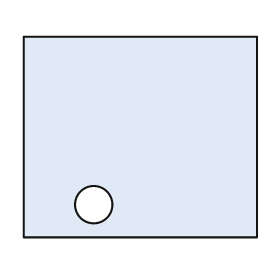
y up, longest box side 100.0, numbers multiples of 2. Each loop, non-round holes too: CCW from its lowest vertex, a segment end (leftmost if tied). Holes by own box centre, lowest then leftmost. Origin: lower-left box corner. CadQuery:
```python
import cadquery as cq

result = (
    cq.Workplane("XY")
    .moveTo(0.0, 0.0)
    .lineTo(100.0, 0.0)
    .lineTo(100.0, 86.0)
    .lineTo(0.0, 86.0)
    .close()
    .moveTo(30.0, 14.0)
    .circle(8.0)
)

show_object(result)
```